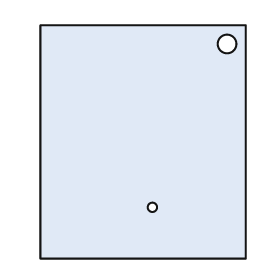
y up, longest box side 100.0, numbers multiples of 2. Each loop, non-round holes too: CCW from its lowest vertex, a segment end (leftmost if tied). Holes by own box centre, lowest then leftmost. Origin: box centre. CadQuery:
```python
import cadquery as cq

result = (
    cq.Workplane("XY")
    .moveTo(-44.0, -50.0)
    .lineTo(44.0, -50.0)
    .lineTo(44.0, 50.0)
    .lineTo(-44.0, 50.0)
    .close()
    .moveTo(4.0, -28.0)
    .circle(2.0)
    .moveTo(36.0, 42.0)
    .circle(4.0)
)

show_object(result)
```